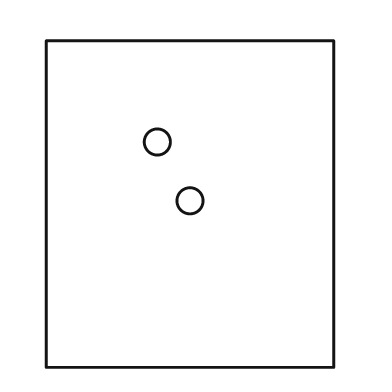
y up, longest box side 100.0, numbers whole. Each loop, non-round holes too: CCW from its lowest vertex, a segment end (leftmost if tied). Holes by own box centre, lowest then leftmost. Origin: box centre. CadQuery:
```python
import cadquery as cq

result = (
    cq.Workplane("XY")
    .moveTo(-44.0, -50.0)
    .lineTo(44.0, -50.0)
    .lineTo(44.0, 50.0)
    .lineTo(-44.0, 50.0)
    .close()
    .moveTo(0.0, 1.0)
    .circle(4.0)
    .moveTo(-10.0, 19.0)
    .circle(4.0)
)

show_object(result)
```